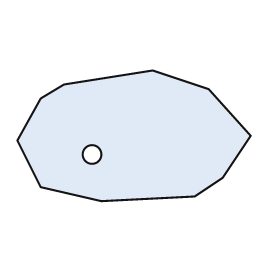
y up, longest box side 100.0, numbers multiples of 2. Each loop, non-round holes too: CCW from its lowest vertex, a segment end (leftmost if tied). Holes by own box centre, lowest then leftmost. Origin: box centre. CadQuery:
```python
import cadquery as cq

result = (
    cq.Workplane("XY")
    .moveTo(-14.0, -28.0)
    .lineTo(26.0, -26.0)
    .lineTo(38.0, -18.0)
    .lineTo(50.0, 0.0)
    .lineTo(32.0, 20.0)
    .lineTo(8.0, 28.0)
    .lineTo(-30.0, 22.0)
    .lineTo(-40.0, 16.0)
    .lineTo(-50.0, -2.0)
    .lineTo(-40.0, -22.0)
    .close()
    .moveTo(-18.0, -8.0)
    .circle(4.0)
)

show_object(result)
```